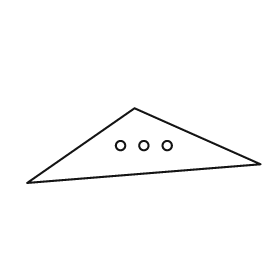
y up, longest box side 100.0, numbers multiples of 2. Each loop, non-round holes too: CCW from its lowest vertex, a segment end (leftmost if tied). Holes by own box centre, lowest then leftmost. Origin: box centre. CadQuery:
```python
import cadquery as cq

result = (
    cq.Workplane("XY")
    .moveTo(-50.0, -16.0)
    .lineTo(50.0, -8.0)
    .lineTo(-4.0, 16.0)
    .close()
    .moveTo(-10.0, 0.0)
    .circle(2.0)
    .moveTo(0.0, 0.0)
    .circle(2.0)
    .moveTo(10.0, 0.0)
    .circle(2.0)
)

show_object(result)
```